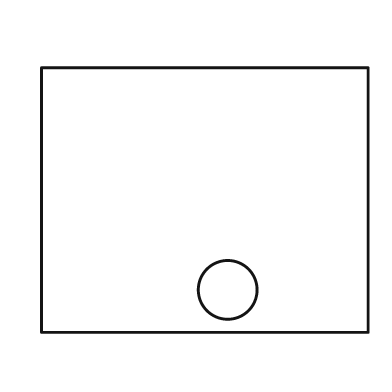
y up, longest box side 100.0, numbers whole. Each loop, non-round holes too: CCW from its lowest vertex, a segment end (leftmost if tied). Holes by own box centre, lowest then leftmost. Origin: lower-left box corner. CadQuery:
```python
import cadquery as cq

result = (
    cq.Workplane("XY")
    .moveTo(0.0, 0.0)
    .lineTo(100.0, 0.0)
    .lineTo(100.0, 81.0)
    .lineTo(0.0, 81.0)
    .close()
    .moveTo(57.0, 13.0)
    .circle(9.0)
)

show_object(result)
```